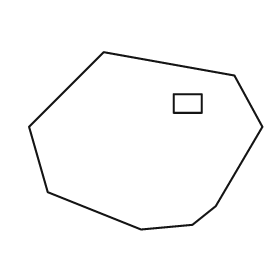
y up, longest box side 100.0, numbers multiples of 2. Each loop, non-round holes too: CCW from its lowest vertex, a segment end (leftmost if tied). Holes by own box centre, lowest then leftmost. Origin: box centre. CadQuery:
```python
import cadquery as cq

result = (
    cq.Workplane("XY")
    .moveTo(-2.0, -38.0)
    .lineTo(20.0, -36.0)
    .lineTo(30.0, -28.0)
    .lineTo(50.0, 6.0)
    .lineTo(38.0, 28.0)
    .lineTo(-18.0, 38.0)
    .lineTo(-50.0, 6.0)
    .lineTo(-42.0, -22.0)
    .close()
    .moveTo(12.0, 12.0)
    .lineTo(24.0, 12.0)
    .lineTo(24.0, 20.0)
    .lineTo(12.0, 20.0)
    .close()
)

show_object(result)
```